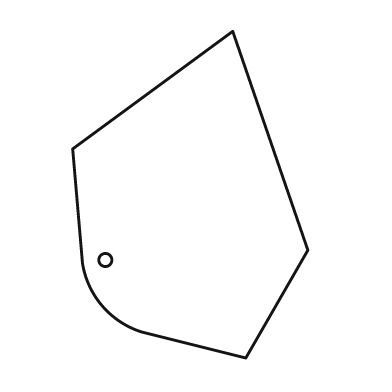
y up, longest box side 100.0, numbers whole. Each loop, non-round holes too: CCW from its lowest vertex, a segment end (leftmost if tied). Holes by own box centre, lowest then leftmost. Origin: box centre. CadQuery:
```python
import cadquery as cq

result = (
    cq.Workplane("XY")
    .moveTo(17.0, -50.0)
    .lineTo(36.0, -17.0)
    .lineTo(13.0, 50.0)
    .lineTo(-36.0, 14.0)
    .lineTo(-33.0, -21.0)
    .threePointArc((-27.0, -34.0), (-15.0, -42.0))
    .close()
    .moveTo(-26.0, -20.0)
    .circle(2.0)
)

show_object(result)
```